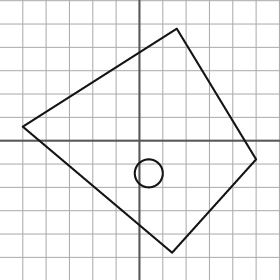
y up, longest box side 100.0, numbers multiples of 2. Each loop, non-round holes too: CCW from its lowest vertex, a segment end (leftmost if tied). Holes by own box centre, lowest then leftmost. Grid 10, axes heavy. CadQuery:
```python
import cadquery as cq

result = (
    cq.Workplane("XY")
    .moveTo(14.0, -48.0)
    .lineTo(50.0, -8.0)
    .lineTo(16.0, 48.0)
    .lineTo(-50.0, 6.0)
    .close()
    .moveTo(4.0, -14.0)
    .circle(6.0)
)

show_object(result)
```